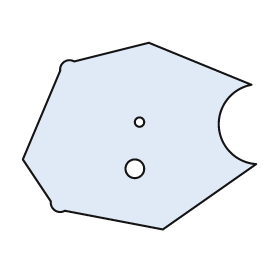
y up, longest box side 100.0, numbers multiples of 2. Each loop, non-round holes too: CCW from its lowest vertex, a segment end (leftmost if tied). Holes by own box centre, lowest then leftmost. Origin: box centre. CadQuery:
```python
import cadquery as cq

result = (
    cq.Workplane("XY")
    .moveTo(10.0, -40.0)
    .lineTo(50.0, -12.0)
    .threePointArc((34.0, 4.0), (48.0, 22.0))
    .lineTo(4.0, 40.0)
    .lineTo(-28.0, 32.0)
    .threePointArc((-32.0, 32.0), (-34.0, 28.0))
    .lineTo(-50.0, -10.0)
    .lineTo(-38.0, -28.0)
    .threePointArc((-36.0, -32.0), (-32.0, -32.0))
    .close()
    .moveTo(-2.0, -14.0)
    .circle(4.0)
    .moveTo(0.0, 6.0)
    .circle(2.0)
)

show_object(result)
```